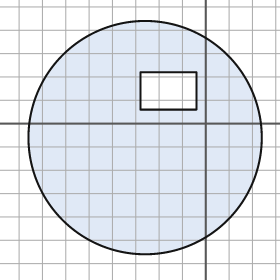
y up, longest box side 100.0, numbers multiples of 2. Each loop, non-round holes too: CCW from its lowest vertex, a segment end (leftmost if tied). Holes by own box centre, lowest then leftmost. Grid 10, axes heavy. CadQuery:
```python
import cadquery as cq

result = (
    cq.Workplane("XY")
    .moveTo(-26.0, -6.0)
    .circle(50.0)
    .moveTo(-28.0, 6.0)
    .lineTo(-4.0, 6.0)
    .lineTo(-4.0, 22.0)
    .lineTo(-28.0, 22.0)
    .close()
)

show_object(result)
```